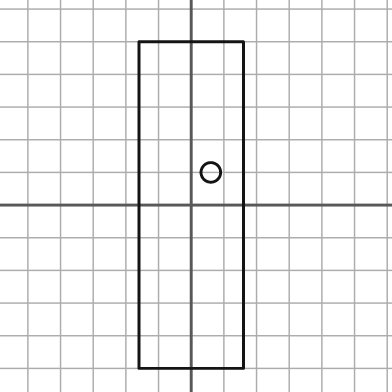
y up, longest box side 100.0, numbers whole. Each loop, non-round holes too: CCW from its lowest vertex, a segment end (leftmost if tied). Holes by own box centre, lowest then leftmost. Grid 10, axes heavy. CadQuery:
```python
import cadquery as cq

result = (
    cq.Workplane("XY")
    .moveTo(-16.0, -50.0)
    .lineTo(16.0, -50.0)
    .lineTo(16.0, 50.0)
    .lineTo(-16.0, 50.0)
    .close()
    .moveTo(6.0, 10.0)
    .circle(3.0)
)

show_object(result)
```